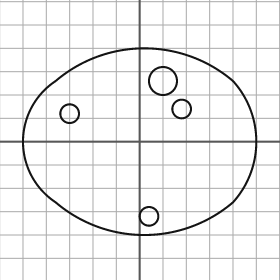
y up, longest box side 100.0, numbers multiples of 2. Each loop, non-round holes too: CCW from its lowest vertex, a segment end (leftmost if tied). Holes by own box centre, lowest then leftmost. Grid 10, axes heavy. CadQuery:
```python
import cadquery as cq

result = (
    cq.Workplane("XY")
    .moveTo(-36.0, -26.0)
    .threePointArc((2.0, -40.0), (40.0, -26.0))
    .threePointArc((50.0, 0.0), (40.0, 26.0))
    .threePointArc((2.0, 40.0), (-36.0, 26.0))
    .threePointArc((-50.0, 0.0), (-36.0, -26.0))
    .close()
    .moveTo(4.0, -32.0)
    .circle(4.0)
    .moveTo(-30.0, 12.0)
    .circle(4.0)
    .moveTo(18.0, 14.0)
    .circle(4.0)
    .moveTo(10.0, 26.0)
    .circle(6.0)
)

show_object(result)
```